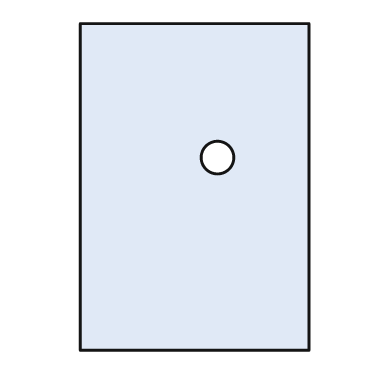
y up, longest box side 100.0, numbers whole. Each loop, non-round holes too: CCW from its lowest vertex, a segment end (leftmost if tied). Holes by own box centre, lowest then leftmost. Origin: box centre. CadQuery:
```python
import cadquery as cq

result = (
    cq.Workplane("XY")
    .moveTo(-35.0, -50.0)
    .lineTo(35.0, -50.0)
    .lineTo(35.0, 50.0)
    .lineTo(-35.0, 50.0)
    .close()
    .moveTo(7.0, 9.0)
    .circle(5.0)
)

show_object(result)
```